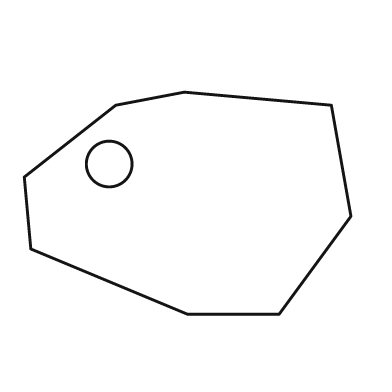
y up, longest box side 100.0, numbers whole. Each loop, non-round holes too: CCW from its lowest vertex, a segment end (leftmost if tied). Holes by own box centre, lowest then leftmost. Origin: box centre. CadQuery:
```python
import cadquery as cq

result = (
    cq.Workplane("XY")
    .moveTo(0.0, -34.0)
    .lineTo(28.0, -34.0)
    .lineTo(50.0, -4.0)
    .lineTo(44.0, 30.0)
    .lineTo(-1.0, 34.0)
    .lineTo(-22.0, 30.0)
    .lineTo(-50.0, 8.0)
    .lineTo(-48.0, -14.0)
    .close()
    .moveTo(-24.0, 12.0)
    .circle(7.0)
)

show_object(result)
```